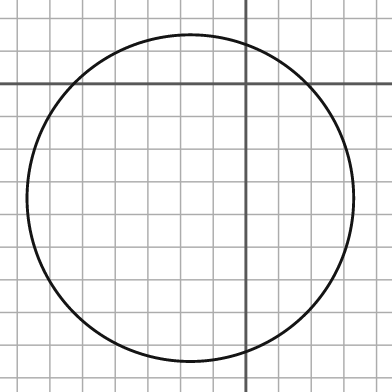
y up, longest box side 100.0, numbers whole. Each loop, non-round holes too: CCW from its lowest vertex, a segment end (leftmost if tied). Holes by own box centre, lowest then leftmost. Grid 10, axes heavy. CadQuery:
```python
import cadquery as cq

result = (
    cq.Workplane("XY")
    .moveTo(-17.0, -35.0)
    .circle(50.0)
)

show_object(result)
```